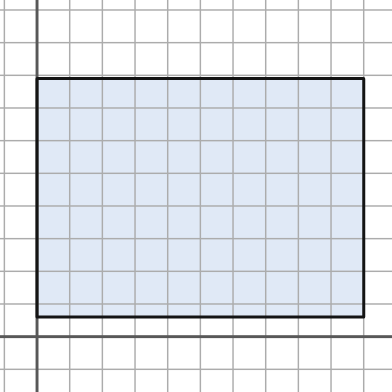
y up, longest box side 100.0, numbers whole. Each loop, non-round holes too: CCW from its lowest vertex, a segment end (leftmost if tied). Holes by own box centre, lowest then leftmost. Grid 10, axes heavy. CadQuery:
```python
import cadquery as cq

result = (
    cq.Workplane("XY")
    .moveTo(0.0, 6.0)
    .lineTo(100.0, 6.0)
    .lineTo(100.0, 79.0)
    .lineTo(0.0, 79.0)
    .close()
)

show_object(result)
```